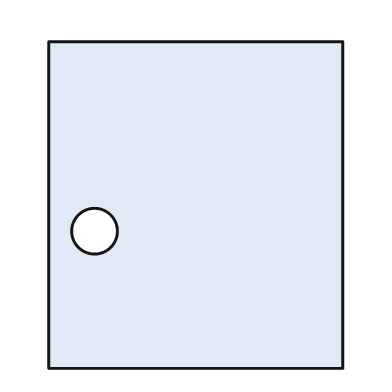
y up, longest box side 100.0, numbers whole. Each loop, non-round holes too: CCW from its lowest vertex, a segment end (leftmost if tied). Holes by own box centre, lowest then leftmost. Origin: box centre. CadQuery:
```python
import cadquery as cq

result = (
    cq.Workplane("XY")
    .moveTo(-45.0, -50.0)
    .lineTo(45.0, -50.0)
    .lineTo(45.0, 50.0)
    .lineTo(-45.0, 50.0)
    .close()
    .moveTo(-31.0, -8.0)
    .circle(7.0)
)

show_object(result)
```